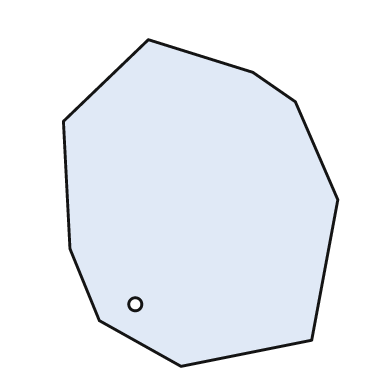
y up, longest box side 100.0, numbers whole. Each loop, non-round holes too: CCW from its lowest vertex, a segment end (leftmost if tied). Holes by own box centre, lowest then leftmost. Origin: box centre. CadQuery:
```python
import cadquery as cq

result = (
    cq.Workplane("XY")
    .moveTo(-6.0, -50.0)
    .lineTo(34.0, -42.0)
    .lineTo(42.0, 1.0)
    .lineTo(29.0, 31.0)
    .lineTo(16.0, 40.0)
    .lineTo(-16.0, 50.0)
    .lineTo(-42.0, 25.0)
    .lineTo(-40.0, -14.0)
    .lineTo(-31.0, -36.0)
    .close()
    .moveTo(-20.0, -31.0)
    .circle(2.0)
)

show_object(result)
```